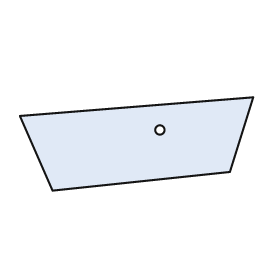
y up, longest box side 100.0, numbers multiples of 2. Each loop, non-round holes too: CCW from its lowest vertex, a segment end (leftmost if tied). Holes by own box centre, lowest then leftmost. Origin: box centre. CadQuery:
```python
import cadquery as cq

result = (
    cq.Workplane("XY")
    .moveTo(-36.0, -20.0)
    .lineTo(40.0, -12.0)
    .lineTo(50.0, 20.0)
    .lineTo(-50.0, 12.0)
    .close()
    .moveTo(10.0, 6.0)
    .circle(2.0)
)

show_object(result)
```